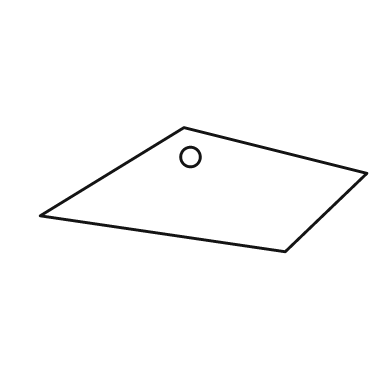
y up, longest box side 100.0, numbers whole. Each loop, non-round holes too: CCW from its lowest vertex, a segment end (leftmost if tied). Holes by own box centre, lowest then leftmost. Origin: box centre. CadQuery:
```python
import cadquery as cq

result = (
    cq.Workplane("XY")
    .moveTo(25.0, -19.0)
    .lineTo(50.0, 5.0)
    .lineTo(-6.0, 19.0)
    .lineTo(-50.0, -8.0)
    .close()
    .moveTo(-4.0, 10.0)
    .circle(3.0)
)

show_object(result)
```